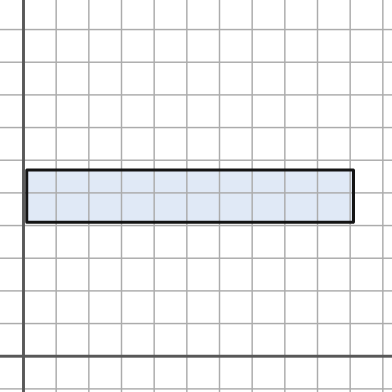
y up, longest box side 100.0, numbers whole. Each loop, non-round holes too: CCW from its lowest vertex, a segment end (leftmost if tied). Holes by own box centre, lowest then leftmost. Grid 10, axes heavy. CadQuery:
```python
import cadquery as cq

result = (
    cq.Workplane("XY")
    .moveTo(1.0, 41.0)
    .lineTo(101.0, 41.0)
    .lineTo(101.0, 57.0)
    .lineTo(1.0, 57.0)
    .close()
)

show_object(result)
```